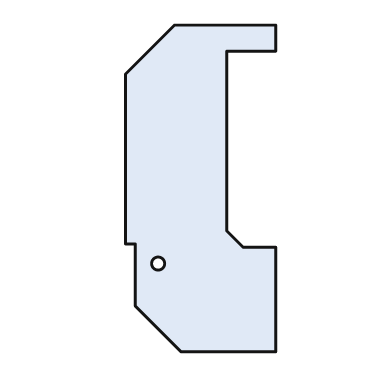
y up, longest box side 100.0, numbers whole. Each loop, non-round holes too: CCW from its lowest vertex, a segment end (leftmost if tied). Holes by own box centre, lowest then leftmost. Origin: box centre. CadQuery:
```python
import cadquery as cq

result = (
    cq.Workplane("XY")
    .moveTo(-6.0, -50.0)
    .lineTo(23.0, -50.0)
    .lineTo(23.0, -18.0)
    .lineTo(13.0, -18.0)
    .lineTo(8.0, -13.0)
    .lineTo(8.0, 42.0)
    .lineTo(23.0, 42.0)
    .lineTo(23.0, 50.0)
    .lineTo(-8.0, 50.0)
    .lineTo(-23.0, 35.0)
    .lineTo(-23.0, -17.0)
    .lineTo(-20.0, -17.0)
    .lineTo(-20.0, -36.0)
    .close()
    .moveTo(-13.0, -23.0)
    .circle(2.0)
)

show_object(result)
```